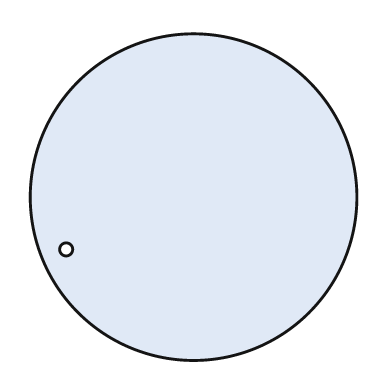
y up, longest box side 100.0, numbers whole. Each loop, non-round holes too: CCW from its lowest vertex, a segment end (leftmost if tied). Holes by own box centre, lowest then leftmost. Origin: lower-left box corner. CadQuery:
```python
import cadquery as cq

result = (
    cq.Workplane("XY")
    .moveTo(50.0, 50.0)
    .circle(50.0)
    .moveTo(11.0, 34.0)
    .circle(2.0)
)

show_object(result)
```